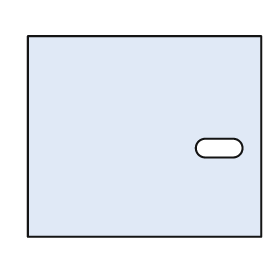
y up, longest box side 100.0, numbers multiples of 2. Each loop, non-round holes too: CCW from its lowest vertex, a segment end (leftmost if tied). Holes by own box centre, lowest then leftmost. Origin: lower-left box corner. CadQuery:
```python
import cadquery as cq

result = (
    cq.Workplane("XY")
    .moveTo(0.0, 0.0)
    .lineTo(100.0, 0.0)
    .lineTo(100.0, 86.0)
    .lineTo(0.0, 86.0)
    .close()
    .moveTo(76.0, 34.0)
    .lineTo(88.0, 34.0)
    .threePointArc((92.0, 38.0), (88.0, 42.0))
    .lineTo(76.0, 42.0)
    .threePointArc((72.0, 38.0), (76.0, 34.0))
    .close()
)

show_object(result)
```